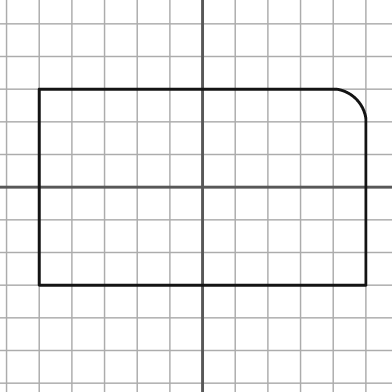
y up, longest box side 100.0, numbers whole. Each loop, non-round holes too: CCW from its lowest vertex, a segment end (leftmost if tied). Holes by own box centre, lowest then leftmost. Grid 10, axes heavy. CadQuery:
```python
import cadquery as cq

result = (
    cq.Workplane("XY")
    .moveTo(-50.0, -30.0)
    .lineTo(50.0, -30.0)
    .lineTo(50.0, 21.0)
    .threePointArc((47.0, 27.0), (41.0, 30.0))
    .lineTo(-50.0, 30.0)
    .close()
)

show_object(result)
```